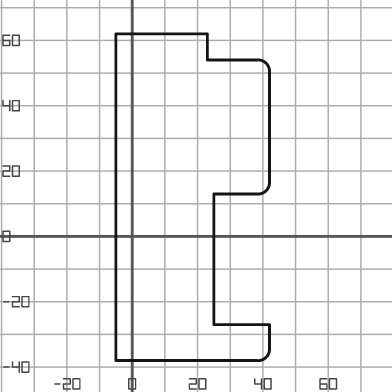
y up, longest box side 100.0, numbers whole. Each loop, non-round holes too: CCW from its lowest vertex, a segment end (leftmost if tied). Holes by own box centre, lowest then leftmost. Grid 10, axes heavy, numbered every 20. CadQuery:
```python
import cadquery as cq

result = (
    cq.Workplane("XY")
    .moveTo(-5.0, -38.0)
    .lineTo(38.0, -38.0)
    .threePointArc((41.0, -37.0), (42.0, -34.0))
    .lineTo(42.0, -27.0)
    .lineTo(25.0, -27.0)
    .lineTo(25.0, 13.0)
    .lineTo(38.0, 13.0)
    .threePointArc((41.0, 14.0), (42.0, 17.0))
    .lineTo(42.0, 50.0)
    .threePointArc((41.0, 53.0), (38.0, 54.0))
    .lineTo(23.0, 54.0)
    .lineTo(23.0, 62.0)
    .lineTo(-5.0, 62.0)
    .close()
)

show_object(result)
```